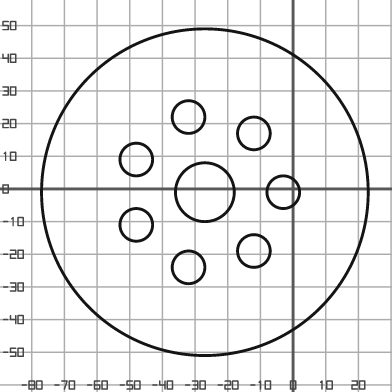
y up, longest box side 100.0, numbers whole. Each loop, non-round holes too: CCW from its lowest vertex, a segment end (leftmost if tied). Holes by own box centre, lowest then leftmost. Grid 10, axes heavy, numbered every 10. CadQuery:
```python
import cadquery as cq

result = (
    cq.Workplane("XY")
    .moveTo(-27.0, -1.0)
    .circle(50.0)
    .moveTo(-32.0, -24.0)
    .circle(5.0)
    .moveTo(-12.0, -19.0)
    .circle(5.0)
    .moveTo(-48.0, -11.0)
    .circle(5.0)
    .moveTo(-27.0, -1.0)
    .circle(9.0)
    .moveTo(-3.0, -1.0)
    .circle(5.0)
    .moveTo(-48.0, 9.0)
    .circle(5.0)
    .moveTo(-12.0, 17.0)
    .circle(5.0)
    .moveTo(-32.0, 22.0)
    .circle(5.0)
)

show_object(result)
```